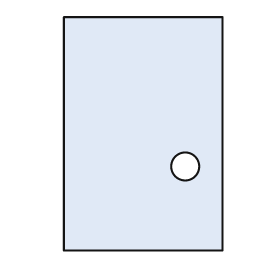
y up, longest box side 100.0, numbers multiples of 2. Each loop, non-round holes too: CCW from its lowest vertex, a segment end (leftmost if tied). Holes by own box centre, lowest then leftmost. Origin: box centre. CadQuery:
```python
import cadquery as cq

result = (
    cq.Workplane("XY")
    .moveTo(-34.0, -50.0)
    .lineTo(34.0, -50.0)
    .lineTo(34.0, 50.0)
    .lineTo(-34.0, 50.0)
    .close()
    .moveTo(18.0, -14.0)
    .circle(6.0)
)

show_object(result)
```